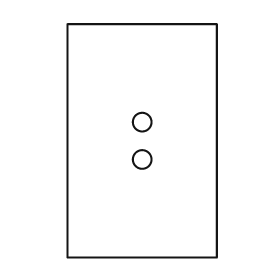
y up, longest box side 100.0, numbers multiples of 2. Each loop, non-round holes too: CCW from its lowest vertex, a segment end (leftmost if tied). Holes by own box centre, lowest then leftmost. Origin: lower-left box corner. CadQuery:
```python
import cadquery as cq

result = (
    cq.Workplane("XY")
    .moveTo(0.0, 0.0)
    .lineTo(64.0, 0.0)
    .lineTo(64.0, 100.0)
    .lineTo(0.0, 100.0)
    .close()
    .moveTo(32.0, 42.0)
    .circle(4.0)
    .moveTo(32.0, 58.0)
    .circle(4.0)
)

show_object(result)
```